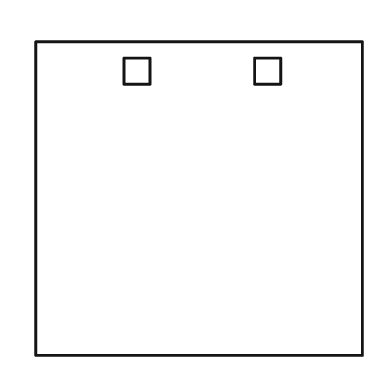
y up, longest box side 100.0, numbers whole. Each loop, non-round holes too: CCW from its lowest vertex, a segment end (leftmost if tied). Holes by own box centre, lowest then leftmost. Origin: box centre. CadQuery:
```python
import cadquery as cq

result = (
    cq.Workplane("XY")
    .moveTo(-50.0, -48.0)
    .lineTo(50.0, -48.0)
    .lineTo(50.0, 48.0)
    .lineTo(-50.0, 48.0)
    .close()
    .moveTo(-23.0, 35.0)
    .lineTo(-15.0, 35.0)
    .lineTo(-15.0, 43.0)
    .lineTo(-23.0, 43.0)
    .close()
    .moveTo(17.0, 35.0)
    .lineTo(25.0, 35.0)
    .lineTo(25.0, 43.0)
    .lineTo(17.0, 43.0)
    .close()
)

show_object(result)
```